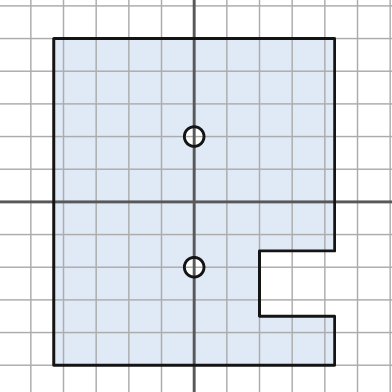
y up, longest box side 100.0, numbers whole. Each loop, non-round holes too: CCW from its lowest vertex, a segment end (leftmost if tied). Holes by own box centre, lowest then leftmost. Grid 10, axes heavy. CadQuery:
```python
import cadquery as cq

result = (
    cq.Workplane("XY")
    .moveTo(-43.0, -50.0)
    .lineTo(43.0, -50.0)
    .lineTo(43.0, -35.0)
    .lineTo(20.0, -35.0)
    .lineTo(20.0, -15.0)
    .lineTo(43.0, -15.0)
    .lineTo(43.0, 50.0)
    .lineTo(-43.0, 50.0)
    .close()
    .moveTo(0.0, -20.0)
    .circle(3.0)
    .moveTo(0.0, 20.0)
    .circle(3.0)
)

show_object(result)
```